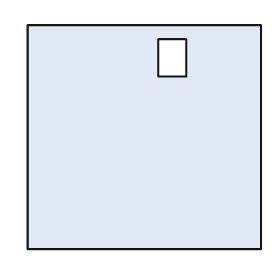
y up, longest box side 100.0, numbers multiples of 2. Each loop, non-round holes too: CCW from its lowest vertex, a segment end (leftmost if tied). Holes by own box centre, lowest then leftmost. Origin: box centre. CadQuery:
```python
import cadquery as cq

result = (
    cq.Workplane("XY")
    .moveTo(-50.0, -48.0)
    .lineTo(50.0, -48.0)
    .lineTo(50.0, 48.0)
    .lineTo(-50.0, 48.0)
    .close()
    .moveTo(6.0, 26.0)
    .lineTo(18.0, 26.0)
    .lineTo(18.0, 42.0)
    .lineTo(6.0, 42.0)
    .close()
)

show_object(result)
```